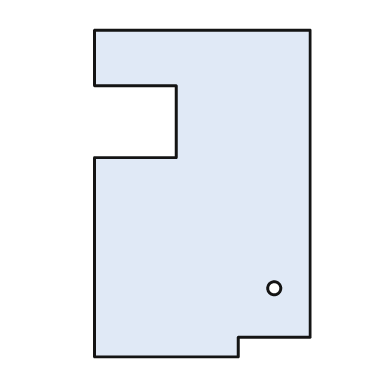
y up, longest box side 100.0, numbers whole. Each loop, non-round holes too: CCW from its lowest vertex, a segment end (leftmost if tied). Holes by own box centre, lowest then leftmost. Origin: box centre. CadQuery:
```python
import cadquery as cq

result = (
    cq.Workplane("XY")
    .moveTo(-33.0, -50.0)
    .lineTo(11.0, -50.0)
    .lineTo(11.0, -44.0)
    .lineTo(33.0, -44.0)
    .lineTo(33.0, 50.0)
    .lineTo(-33.0, 50.0)
    .lineTo(-33.0, 33.0)
    .lineTo(-8.0, 33.0)
    .lineTo(-8.0, 11.0)
    .lineTo(-33.0, 11.0)
    .close()
    .moveTo(22.0, -29.0)
    .circle(2.0)
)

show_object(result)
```